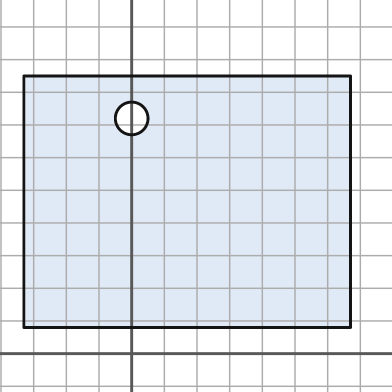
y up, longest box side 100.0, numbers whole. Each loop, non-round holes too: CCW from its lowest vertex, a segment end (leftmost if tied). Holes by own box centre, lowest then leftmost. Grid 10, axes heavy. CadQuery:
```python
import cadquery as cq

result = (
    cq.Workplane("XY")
    .moveTo(-33.0, 8.0)
    .lineTo(67.0, 8.0)
    .lineTo(67.0, 85.0)
    .lineTo(-33.0, 85.0)
    .close()
    .moveTo(0.0, 72.0)
    .circle(5.0)
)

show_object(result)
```